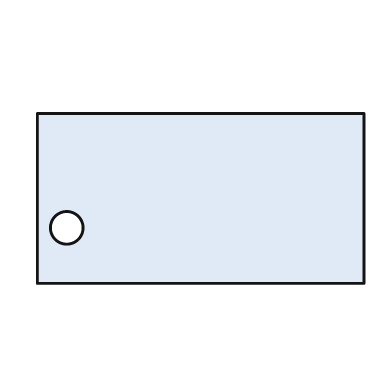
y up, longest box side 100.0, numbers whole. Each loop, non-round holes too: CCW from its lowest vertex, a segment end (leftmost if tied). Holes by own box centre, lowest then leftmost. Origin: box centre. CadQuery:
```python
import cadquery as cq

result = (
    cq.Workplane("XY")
    .moveTo(-50.0, -26.0)
    .lineTo(50.0, -26.0)
    .lineTo(50.0, 26.0)
    .lineTo(-50.0, 26.0)
    .close()
    .moveTo(-41.0, -9.0)
    .circle(5.0)
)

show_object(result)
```